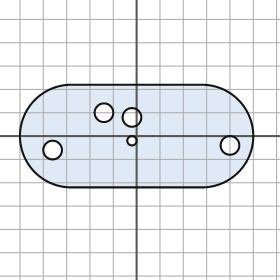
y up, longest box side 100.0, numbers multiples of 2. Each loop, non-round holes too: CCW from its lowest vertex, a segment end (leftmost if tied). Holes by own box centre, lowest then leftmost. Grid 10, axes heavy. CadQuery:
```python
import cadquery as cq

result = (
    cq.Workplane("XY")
    .moveTo(-28.0, -22.0)
    .lineTo(28.0, -22.0)
    .threePointArc((50.0, 0.0), (28.0, 22.0))
    .lineTo(-28.0, 22.0)
    .threePointArc((-50.0, 0.0), (-28.0, -22.0))
    .close()
    .moveTo(-36.0, -6.0)
    .circle(4.0)
    .moveTo(40.0, -4.0)
    .circle(4.0)
    .moveTo(-2.0, -2.0)
    .circle(2.0)
    .moveTo(-2.0, 8.0)
    .circle(4.0)
    .moveTo(-14.0, 10.0)
    .circle(4.0)
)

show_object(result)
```